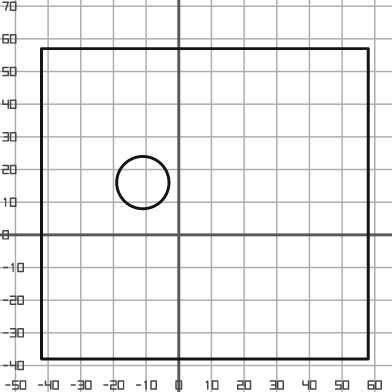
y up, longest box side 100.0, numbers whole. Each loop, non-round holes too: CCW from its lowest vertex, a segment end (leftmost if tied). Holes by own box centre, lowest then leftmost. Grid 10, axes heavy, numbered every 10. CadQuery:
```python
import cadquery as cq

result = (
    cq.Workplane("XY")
    .moveTo(-42.0, -38.0)
    .lineTo(58.0, -38.0)
    .lineTo(58.0, 57.0)
    .lineTo(-42.0, 57.0)
    .close()
    .moveTo(-11.0, 16.0)
    .circle(8.0)
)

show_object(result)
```